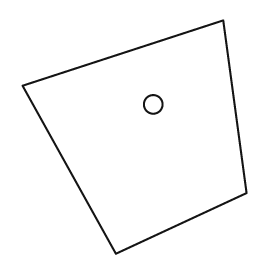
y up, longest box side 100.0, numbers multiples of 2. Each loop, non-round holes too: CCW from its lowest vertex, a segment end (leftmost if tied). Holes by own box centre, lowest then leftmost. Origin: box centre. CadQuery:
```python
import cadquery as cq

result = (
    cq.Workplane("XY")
    .moveTo(-8.0, -50.0)
    .lineTo(48.0, -24.0)
    .lineTo(38.0, 50.0)
    .lineTo(-48.0, 22.0)
    .close()
    .moveTo(8.0, 14.0)
    .circle(4.0)
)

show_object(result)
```